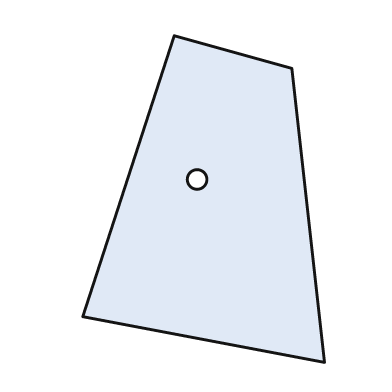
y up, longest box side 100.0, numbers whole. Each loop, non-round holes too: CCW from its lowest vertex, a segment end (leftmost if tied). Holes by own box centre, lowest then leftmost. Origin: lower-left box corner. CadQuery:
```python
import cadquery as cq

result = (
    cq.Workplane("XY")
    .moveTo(74.0, 0.0)
    .lineTo(64.0, 90.0)
    .lineTo(28.0, 100.0)
    .lineTo(0.0, 14.0)
    .close()
    .moveTo(35.0, 56.0)
    .circle(3.0)
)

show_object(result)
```